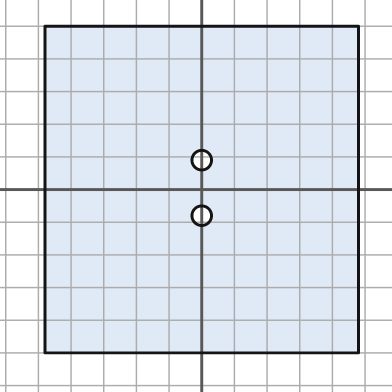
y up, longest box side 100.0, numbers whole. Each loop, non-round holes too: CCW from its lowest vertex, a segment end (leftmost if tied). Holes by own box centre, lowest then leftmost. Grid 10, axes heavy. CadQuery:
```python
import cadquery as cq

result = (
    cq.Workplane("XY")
    .moveTo(-48.0, -50.0)
    .lineTo(48.0, -50.0)
    .lineTo(48.0, 50.0)
    .lineTo(-48.0, 50.0)
    .close()
    .moveTo(0.0, -8.0)
    .circle(3.0)
    .moveTo(0.0, 9.0)
    .circle(3.0)
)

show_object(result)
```